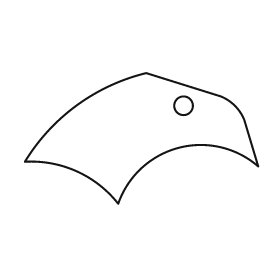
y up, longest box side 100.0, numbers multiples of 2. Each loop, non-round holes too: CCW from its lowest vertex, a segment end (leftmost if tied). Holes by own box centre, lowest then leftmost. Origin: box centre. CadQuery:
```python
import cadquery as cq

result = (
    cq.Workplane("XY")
    .moveTo(-10.0, -28.0)
    .threePointArc((16.0, -4.0), (50.0, -12.0))
    .lineTo(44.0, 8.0)
    .threePointArc((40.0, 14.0), (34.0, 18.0))
    .lineTo(2.0, 28.0)
    .threePointArc((-28.0, 14.0), (-50.0, -10.0))
    .threePointArc((-28.0, -14.0), (-10.0, -28.0))
    .close()
    .moveTo(18.0, 14.0)
    .circle(4.0)
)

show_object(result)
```